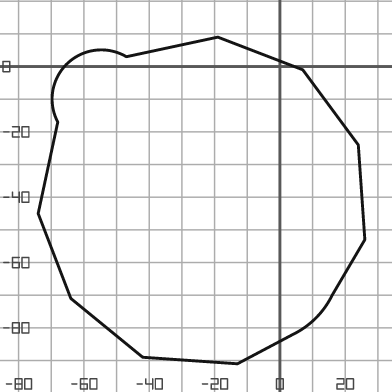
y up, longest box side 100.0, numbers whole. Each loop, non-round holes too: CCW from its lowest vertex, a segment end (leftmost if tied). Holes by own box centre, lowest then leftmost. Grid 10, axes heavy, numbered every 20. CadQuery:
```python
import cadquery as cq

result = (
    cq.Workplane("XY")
    .moveTo(-13.0, -91.0)
    .lineTo(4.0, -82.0)
    .threePointArc((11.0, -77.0), (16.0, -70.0))
    .lineTo(26.0, -53.0)
    .lineTo(24.0, -24.0)
    .lineTo(7.0, -1.0)
    .lineTo(-19.0, 9.0)
    .lineTo(-47.0, 3.0)
    .threePointArc((-65.0, 1.0), (-68.0, -17.0))
    .lineTo(-74.0, -45.0)
    .lineTo(-64.0, -71.0)
    .lineTo(-42.0, -89.0)
    .close()
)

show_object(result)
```